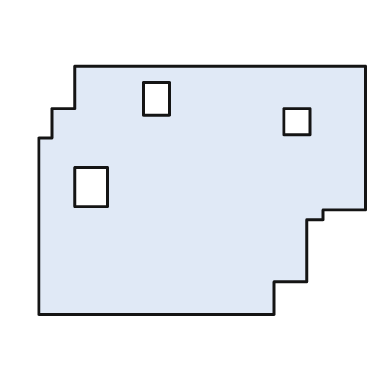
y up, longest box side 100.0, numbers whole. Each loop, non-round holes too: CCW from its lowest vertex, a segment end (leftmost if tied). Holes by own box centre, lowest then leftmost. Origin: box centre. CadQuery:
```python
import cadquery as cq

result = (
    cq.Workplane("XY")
    .moveTo(-50.0, -38.0)
    .lineTo(22.0, -38.0)
    .lineTo(22.0, -28.0)
    .lineTo(32.0, -28.0)
    .lineTo(32.0, -9.0)
    .lineTo(37.0, -9.0)
    .lineTo(37.0, -6.0)
    .lineTo(50.0, -6.0)
    .lineTo(50.0, 38.0)
    .lineTo(-39.0, 38.0)
    .lineTo(-39.0, 25.0)
    .lineTo(-46.0, 25.0)
    .lineTo(-46.0, 16.0)
    .lineTo(-50.0, 16.0)
    .close()
    .moveTo(-39.0, -5.0)
    .lineTo(-29.0, -5.0)
    .lineTo(-29.0, 7.0)
    .lineTo(-39.0, 7.0)
    .close()
    .moveTo(25.0, 17.0)
    .lineTo(33.0, 17.0)
    .lineTo(33.0, 25.0)
    .lineTo(25.0, 25.0)
    .close()
    .moveTo(-18.0, 23.0)
    .lineTo(-10.0, 23.0)
    .lineTo(-10.0, 33.0)
    .lineTo(-18.0, 33.0)
    .close()
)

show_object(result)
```